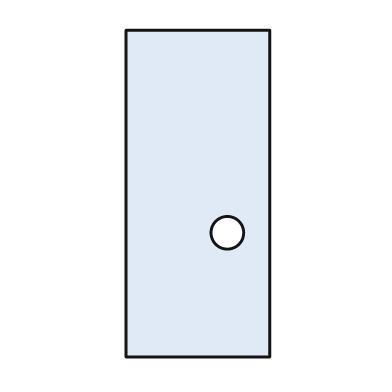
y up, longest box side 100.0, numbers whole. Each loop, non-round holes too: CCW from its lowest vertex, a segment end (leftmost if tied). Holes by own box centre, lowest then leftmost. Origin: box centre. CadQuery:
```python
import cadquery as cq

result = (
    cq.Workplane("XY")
    .moveTo(-22.0, -50.0)
    .lineTo(22.0, -50.0)
    .lineTo(22.0, 50.0)
    .lineTo(-22.0, 50.0)
    .close()
    .moveTo(9.0, -12.0)
    .circle(5.0)
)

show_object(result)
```